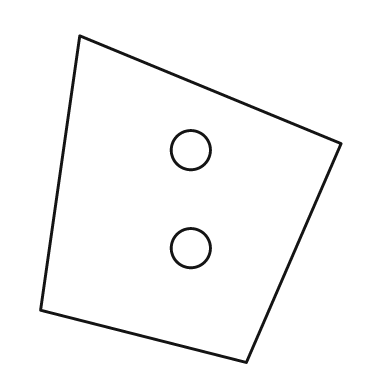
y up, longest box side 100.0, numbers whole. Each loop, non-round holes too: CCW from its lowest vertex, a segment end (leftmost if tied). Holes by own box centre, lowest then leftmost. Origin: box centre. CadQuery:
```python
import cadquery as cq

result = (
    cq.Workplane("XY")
    .moveTo(17.0, -50.0)
    .lineTo(46.0, 17.0)
    .lineTo(-34.0, 50.0)
    .lineTo(-46.0, -34.0)
    .close()
    .moveTo(0.0, -15.0)
    .circle(6.0)
    .moveTo(0.0, 15.0)
    .circle(6.0)
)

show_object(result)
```